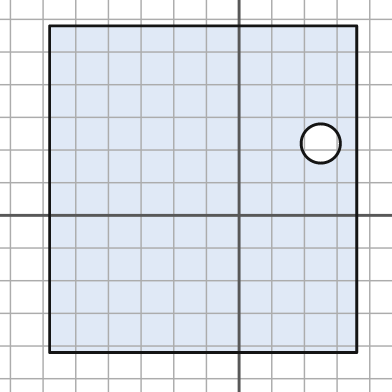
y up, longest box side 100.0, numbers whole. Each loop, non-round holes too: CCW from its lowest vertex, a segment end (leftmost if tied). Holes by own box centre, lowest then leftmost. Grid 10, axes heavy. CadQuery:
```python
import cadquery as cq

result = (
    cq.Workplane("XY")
    .moveTo(-58.0, -42.0)
    .lineTo(36.0, -42.0)
    .lineTo(36.0, 58.0)
    .lineTo(-58.0, 58.0)
    .close()
    .moveTo(25.0, 22.0)
    .circle(6.0)
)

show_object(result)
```